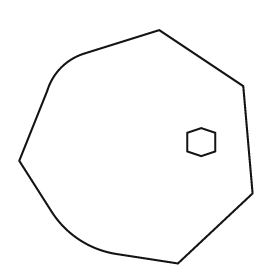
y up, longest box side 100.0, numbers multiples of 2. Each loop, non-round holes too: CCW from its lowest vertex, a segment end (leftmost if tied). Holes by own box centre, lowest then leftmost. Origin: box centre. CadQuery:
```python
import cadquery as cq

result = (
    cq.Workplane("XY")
    .moveTo(18.0, -50.0)
    .lineTo(50.0, -20.0)
    .lineTo(46.0, 26.0)
    .lineTo(10.0, 50.0)
    .lineTo(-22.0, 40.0)
    .threePointArc((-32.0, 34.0), (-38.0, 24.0))
    .lineTo(-50.0, -6.0)
    .lineTo(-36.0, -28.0)
    .threePointArc((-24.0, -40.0), (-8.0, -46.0))
    .close()
    .moveTo(28.0, -4.0)
    .lineTo(34.0, -2.0)
    .lineTo(34.0, 6.0)
    .lineTo(28.0, 8.0)
    .lineTo(22.0, 6.0)
    .lineTo(22.0, -2.0)
    .close()
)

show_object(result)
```